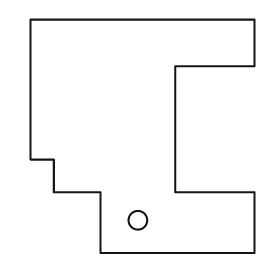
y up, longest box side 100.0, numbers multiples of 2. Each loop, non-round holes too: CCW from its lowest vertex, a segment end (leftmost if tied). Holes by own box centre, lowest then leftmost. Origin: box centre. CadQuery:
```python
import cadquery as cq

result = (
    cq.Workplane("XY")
    .moveTo(-18.0, -50.0)
    .lineTo(48.0, -50.0)
    .lineTo(48.0, -24.0)
    .lineTo(14.0, -24.0)
    .lineTo(14.0, 30.0)
    .lineTo(48.0, 30.0)
    .lineTo(48.0, 50.0)
    .lineTo(-48.0, 50.0)
    .lineTo(-48.0, -10.0)
    .lineTo(-38.0, -10.0)
    .lineTo(-38.0, -24.0)
    .lineTo(-18.0, -24.0)
    .close()
    .moveTo(-2.0, -36.0)
    .circle(4.0)
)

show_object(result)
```